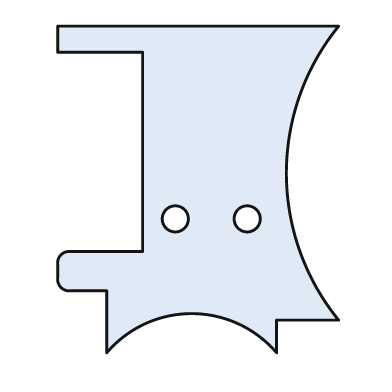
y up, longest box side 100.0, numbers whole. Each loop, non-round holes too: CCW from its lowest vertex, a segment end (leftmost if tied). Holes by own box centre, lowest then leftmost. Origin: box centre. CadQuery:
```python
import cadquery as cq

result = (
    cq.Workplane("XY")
    .moveTo(-28.0, -50.0)
    .threePointArc((-2.0, -38.0), (24.0, -50.0))
    .lineTo(24.0, -40.0)
    .lineTo(43.0, -40.0)
    .threePointArc((27.0, 5.0), (43.0, 50.0))
    .lineTo(-43.0, 50.0)
    .lineTo(-43.0, 42.0)
    .lineTo(-17.0, 42.0)
    .lineTo(-17.0, -19.0)
    .lineTo(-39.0, -19.0)
    .threePointArc((-42.0, -20.0), (-43.0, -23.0))
    .lineTo(-43.0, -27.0)
    .threePointArc((-42.0, -30.0), (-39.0, -31.0))
    .lineTo(-28.0, -31.0)
    .close()
    .moveTo(-7.0, -9.0)
    .circle(4.0)
    .moveTo(15.0, -9.0)
    .circle(4.0)
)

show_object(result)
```